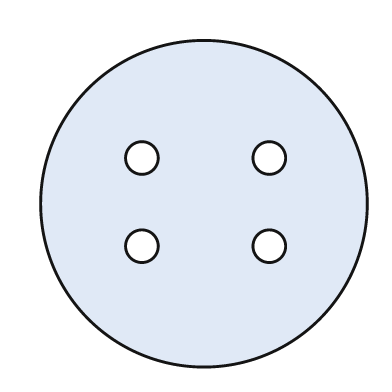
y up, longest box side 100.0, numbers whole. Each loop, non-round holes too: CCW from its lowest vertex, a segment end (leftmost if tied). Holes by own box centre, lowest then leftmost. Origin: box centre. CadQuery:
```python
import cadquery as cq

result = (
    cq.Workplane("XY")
    .moveTo(0.0, 0.0)
    .circle(50.0)
    .moveTo(-19.0, -13.0)
    .circle(5.0)
    .moveTo(20.0, -13.0)
    .circle(5.0)
    .moveTo(-19.0, 14.0)
    .circle(5.0)
    .moveTo(20.0, 14.0)
    .circle(5.0)
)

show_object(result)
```